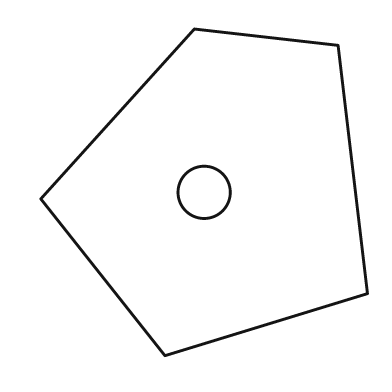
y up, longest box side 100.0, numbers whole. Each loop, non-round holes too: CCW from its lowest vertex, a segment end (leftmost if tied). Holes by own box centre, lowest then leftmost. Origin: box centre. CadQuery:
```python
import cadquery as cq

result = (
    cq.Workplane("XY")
    .moveTo(-12.0, -50.0)
    .lineTo(50.0, -31.0)
    .lineTo(41.0, 45.0)
    .lineTo(-3.0, 50.0)
    .lineTo(-50.0, -2.0)
    .close()
    .moveTo(0.0, 0.0)
    .circle(8.0)
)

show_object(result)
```